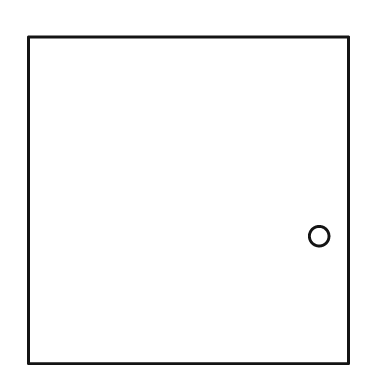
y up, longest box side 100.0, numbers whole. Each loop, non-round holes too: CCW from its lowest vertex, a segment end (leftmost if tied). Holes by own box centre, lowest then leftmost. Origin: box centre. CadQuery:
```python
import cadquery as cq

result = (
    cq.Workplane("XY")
    .moveTo(-49.0, -50.0)
    .lineTo(49.0, -50.0)
    .lineTo(49.0, 50.0)
    .lineTo(-49.0, 50.0)
    .close()
    .moveTo(40.0, -11.0)
    .circle(3.0)
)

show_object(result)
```